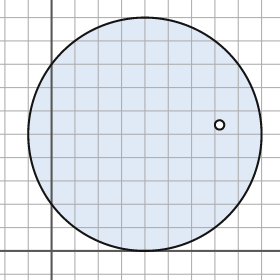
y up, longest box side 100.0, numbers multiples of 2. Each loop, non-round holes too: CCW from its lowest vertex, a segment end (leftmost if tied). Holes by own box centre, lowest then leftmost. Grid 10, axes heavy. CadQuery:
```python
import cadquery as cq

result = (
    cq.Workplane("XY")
    .moveTo(40.0, 50.0)
    .circle(50.0)
    .moveTo(72.0, 54.0)
    .circle(2.0)
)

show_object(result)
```